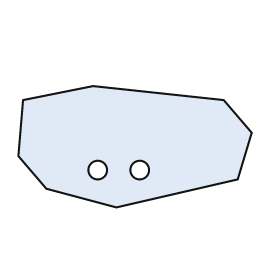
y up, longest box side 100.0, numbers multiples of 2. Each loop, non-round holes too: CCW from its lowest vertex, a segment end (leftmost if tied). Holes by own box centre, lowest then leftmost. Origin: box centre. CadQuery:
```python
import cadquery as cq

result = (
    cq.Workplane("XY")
    .moveTo(-8.0, -26.0)
    .lineTo(44.0, -14.0)
    .lineTo(50.0, 6.0)
    .lineTo(38.0, 20.0)
    .lineTo(-18.0, 26.0)
    .lineTo(-48.0, 20.0)
    .lineTo(-50.0, -4.0)
    .lineTo(-38.0, -18.0)
    .close()
    .moveTo(-16.0, -10.0)
    .circle(4.0)
    .moveTo(2.0, -10.0)
    .circle(4.0)
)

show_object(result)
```